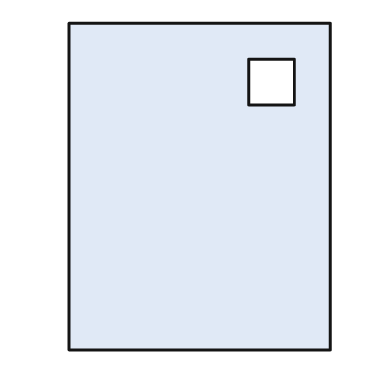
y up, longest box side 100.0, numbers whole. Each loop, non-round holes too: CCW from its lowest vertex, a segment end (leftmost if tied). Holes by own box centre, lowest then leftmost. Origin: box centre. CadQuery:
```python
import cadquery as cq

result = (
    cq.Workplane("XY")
    .moveTo(-40.0, -50.0)
    .lineTo(40.0, -50.0)
    .lineTo(40.0, 50.0)
    .lineTo(-40.0, 50.0)
    .close()
    .moveTo(15.0, 25.0)
    .lineTo(29.0, 25.0)
    .lineTo(29.0, 39.0)
    .lineTo(15.0, 39.0)
    .close()
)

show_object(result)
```